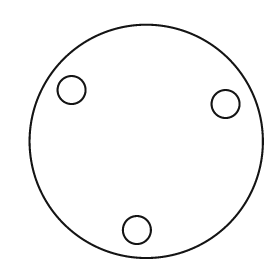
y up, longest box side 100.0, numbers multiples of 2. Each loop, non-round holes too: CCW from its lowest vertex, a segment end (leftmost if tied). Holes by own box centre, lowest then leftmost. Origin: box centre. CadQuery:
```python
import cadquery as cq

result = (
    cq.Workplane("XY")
    .moveTo(0.0, 0.0)
    .circle(50.0)
    .moveTo(-4.0, -38.0)
    .circle(6.0)
    .moveTo(34.0, 16.0)
    .circle(6.0)
    .moveTo(-32.0, 22.0)
    .circle(6.0)
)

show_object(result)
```